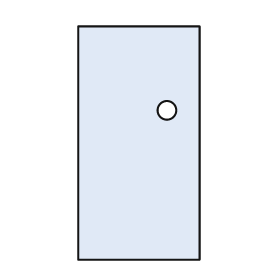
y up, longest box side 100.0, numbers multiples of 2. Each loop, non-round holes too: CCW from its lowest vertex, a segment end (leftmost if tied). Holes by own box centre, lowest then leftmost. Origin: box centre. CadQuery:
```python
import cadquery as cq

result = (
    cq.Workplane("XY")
    .moveTo(-26.0, -50.0)
    .lineTo(26.0, -50.0)
    .lineTo(26.0, 50.0)
    .lineTo(-26.0, 50.0)
    .close()
    .moveTo(12.0, 14.0)
    .circle(4.0)
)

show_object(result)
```